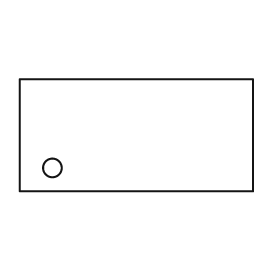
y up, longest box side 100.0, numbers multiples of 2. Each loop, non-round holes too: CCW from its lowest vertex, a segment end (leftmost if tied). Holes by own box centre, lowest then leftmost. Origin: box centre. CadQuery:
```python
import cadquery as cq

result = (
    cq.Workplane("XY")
    .moveTo(-50.0, -24.0)
    .lineTo(50.0, -24.0)
    .lineTo(50.0, 24.0)
    .lineTo(-50.0, 24.0)
    .close()
    .moveTo(-36.0, -14.0)
    .circle(4.0)
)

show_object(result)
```